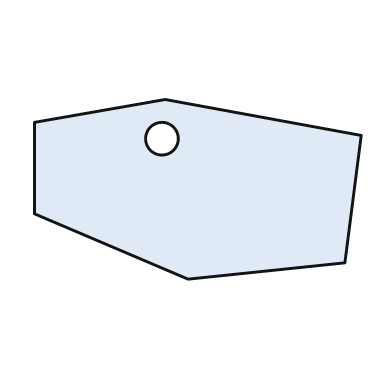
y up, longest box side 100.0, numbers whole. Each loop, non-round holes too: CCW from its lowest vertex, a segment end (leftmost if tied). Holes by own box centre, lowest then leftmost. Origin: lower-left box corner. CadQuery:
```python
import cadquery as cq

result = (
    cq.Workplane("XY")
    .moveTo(47.0, 0.0)
    .lineTo(95.0, 5.0)
    .lineTo(100.0, 44.0)
    .lineTo(40.0, 55.0)
    .lineTo(0.0, 48.0)
    .lineTo(0.0, 20.0)
    .close()
    .moveTo(39.0, 43.0)
    .circle(5.0)
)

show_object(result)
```